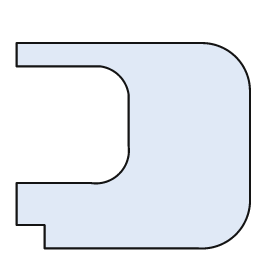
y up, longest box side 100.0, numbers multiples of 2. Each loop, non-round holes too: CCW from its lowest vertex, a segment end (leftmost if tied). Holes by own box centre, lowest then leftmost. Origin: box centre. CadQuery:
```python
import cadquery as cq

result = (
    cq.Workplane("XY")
    .moveTo(-38.0, -44.0)
    .lineTo(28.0, -44.0)
    .threePointArc((44.0, -38.0), (50.0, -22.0))
    .lineTo(50.0, 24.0)
    .threePointArc((44.0, 38.0), (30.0, 44.0))
    .lineTo(-50.0, 44.0)
    .lineTo(-50.0, 34.0)
    .lineTo(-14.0, 34.0)
    .threePointArc((-6.0, 30.0), (-2.0, 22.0))
    .lineTo(-2.0, 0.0)
    .threePointArc((-6.0, -12.0), (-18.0, -16.0))
    .lineTo(-50.0, -16.0)
    .lineTo(-50.0, -34.0)
    .lineTo(-38.0, -34.0)
    .close()
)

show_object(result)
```